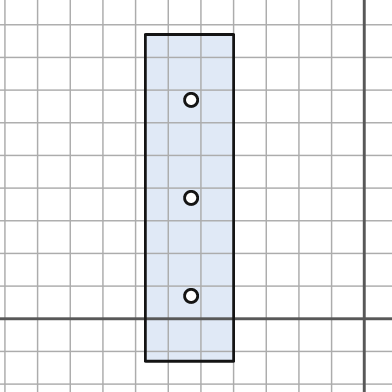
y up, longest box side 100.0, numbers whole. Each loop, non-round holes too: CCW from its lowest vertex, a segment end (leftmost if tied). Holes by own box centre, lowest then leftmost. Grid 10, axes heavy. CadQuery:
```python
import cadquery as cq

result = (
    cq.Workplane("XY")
    .moveTo(-67.0, -13.0)
    .lineTo(-40.0, -13.0)
    .lineTo(-40.0, 87.0)
    .lineTo(-67.0, 87.0)
    .close()
    .moveTo(-53.0, 7.0)
    .circle(2.0)
    .moveTo(-53.0, 37.0)
    .circle(2.0)
    .moveTo(-53.0, 67.0)
    .circle(2.0)
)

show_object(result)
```